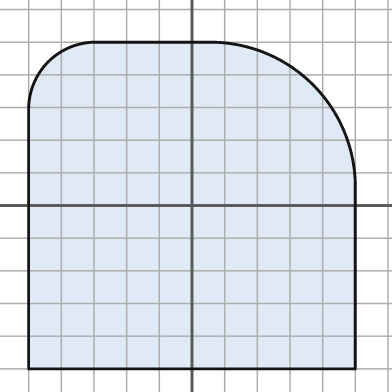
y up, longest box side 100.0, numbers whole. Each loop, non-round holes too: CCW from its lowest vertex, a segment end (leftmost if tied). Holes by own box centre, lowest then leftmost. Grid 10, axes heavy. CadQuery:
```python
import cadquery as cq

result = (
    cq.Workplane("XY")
    .moveTo(-50.0, -50.0)
    .lineTo(50.0, -50.0)
    .lineTo(50.0, 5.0)
    .threePointArc((37.0, 37.0), (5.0, 50.0))
    .lineTo(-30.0, 50.0)
    .threePointArc((-44.0, 44.0), (-50.0, 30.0))
    .close()
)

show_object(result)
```